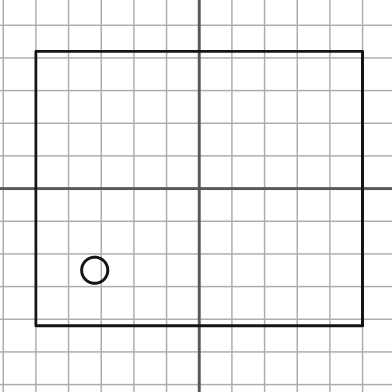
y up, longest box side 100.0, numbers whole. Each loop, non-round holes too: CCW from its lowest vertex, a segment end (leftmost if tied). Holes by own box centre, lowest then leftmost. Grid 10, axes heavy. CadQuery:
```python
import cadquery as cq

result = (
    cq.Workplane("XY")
    .moveTo(-50.0, -42.0)
    .lineTo(50.0, -42.0)
    .lineTo(50.0, 42.0)
    .lineTo(-50.0, 42.0)
    .close()
    .moveTo(-32.0, -25.0)
    .circle(4.0)
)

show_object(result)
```